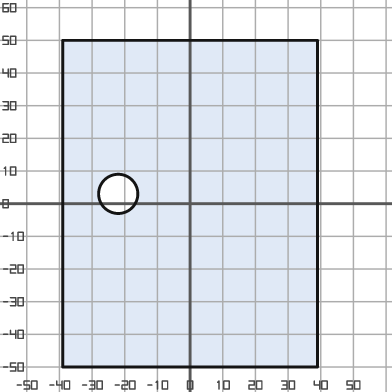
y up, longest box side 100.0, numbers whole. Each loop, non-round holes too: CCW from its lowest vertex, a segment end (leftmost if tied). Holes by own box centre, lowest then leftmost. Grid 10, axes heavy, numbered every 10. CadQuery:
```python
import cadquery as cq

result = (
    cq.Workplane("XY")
    .moveTo(-39.0, -50.0)
    .lineTo(39.0, -50.0)
    .lineTo(39.0, 50.0)
    .lineTo(-39.0, 50.0)
    .close()
    .moveTo(-22.0, 3.0)
    .circle(6.0)
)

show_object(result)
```